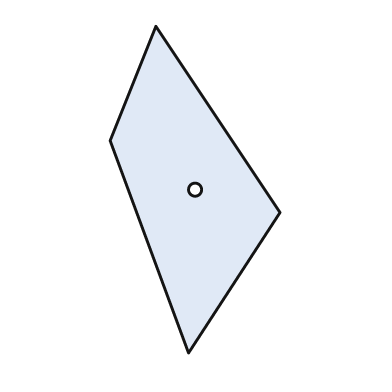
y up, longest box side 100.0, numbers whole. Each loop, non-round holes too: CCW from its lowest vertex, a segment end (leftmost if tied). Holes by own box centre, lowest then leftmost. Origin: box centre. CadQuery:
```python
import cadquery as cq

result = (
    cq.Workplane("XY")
    .moveTo(-2.0, -50.0)
    .lineTo(26.0, -7.0)
    .lineTo(-12.0, 50.0)
    .lineTo(-26.0, 15.0)
    .close()
    .moveTo(0.0, 0.0)
    .circle(2.0)
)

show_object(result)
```